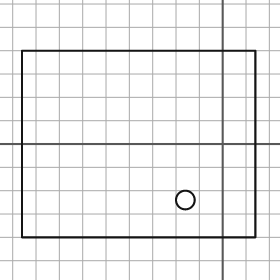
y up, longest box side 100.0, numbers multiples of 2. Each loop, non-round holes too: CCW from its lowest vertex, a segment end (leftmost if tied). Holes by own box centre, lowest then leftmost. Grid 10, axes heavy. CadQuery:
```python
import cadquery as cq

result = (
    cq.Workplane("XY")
    .moveTo(-86.0, -40.0)
    .lineTo(14.0, -40.0)
    .lineTo(14.0, 40.0)
    .lineTo(-86.0, 40.0)
    .close()
    .moveTo(-16.0, -24.0)
    .circle(4.0)
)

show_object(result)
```